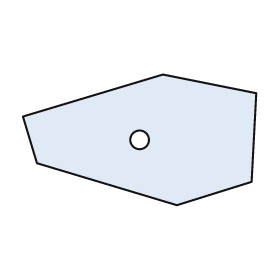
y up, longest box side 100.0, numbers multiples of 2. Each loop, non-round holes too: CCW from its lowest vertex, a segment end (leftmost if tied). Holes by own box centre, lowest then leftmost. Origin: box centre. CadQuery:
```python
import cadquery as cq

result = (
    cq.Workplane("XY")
    .moveTo(16.0, -28.0)
    .lineTo(48.0, -18.0)
    .lineTo(50.0, 20.0)
    .lineTo(10.0, 28.0)
    .lineTo(-50.0, 10.0)
    .lineTo(-44.0, -10.0)
    .close()
    .moveTo(0.0, 0.0)
    .circle(4.0)
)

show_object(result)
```